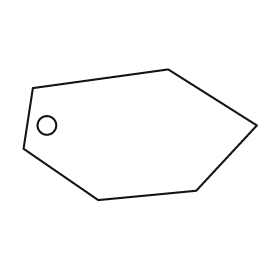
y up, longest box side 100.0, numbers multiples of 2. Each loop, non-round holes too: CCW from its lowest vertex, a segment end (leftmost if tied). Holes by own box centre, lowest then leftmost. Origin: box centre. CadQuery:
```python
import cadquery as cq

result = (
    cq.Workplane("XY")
    .moveTo(-18.0, -28.0)
    .lineTo(24.0, -24.0)
    .lineTo(50.0, 4.0)
    .lineTo(12.0, 28.0)
    .lineTo(-46.0, 20.0)
    .lineTo(-50.0, -6.0)
    .close()
    .moveTo(-40.0, 4.0)
    .circle(4.0)
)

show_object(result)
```